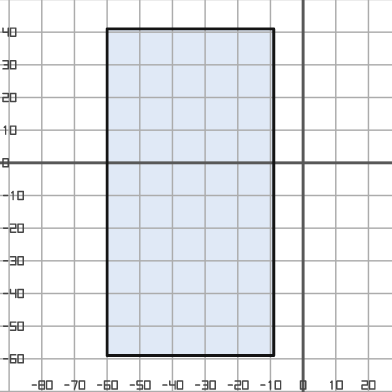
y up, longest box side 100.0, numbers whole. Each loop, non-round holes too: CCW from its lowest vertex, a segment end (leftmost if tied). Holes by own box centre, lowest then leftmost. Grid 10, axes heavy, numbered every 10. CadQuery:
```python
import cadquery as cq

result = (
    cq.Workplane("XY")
    .moveTo(-60.0, -59.0)
    .lineTo(-9.0, -59.0)
    .lineTo(-9.0, 41.0)
    .lineTo(-60.0, 41.0)
    .close()
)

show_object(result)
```